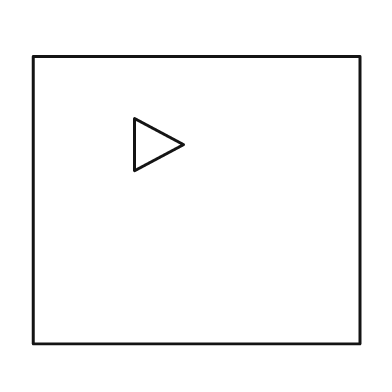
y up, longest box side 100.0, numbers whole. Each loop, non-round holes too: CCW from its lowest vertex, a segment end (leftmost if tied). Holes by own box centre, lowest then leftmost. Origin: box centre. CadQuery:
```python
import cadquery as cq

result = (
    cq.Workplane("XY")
    .moveTo(-50.0, -44.0)
    .lineTo(50.0, -44.0)
    .lineTo(50.0, 44.0)
    .lineTo(-50.0, 44.0)
    .close()
    .moveTo(-19.0, 9.0)
    .lineTo(-4.0, 17.0)
    .lineTo(-19.0, 25.0)
    .close()
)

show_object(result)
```